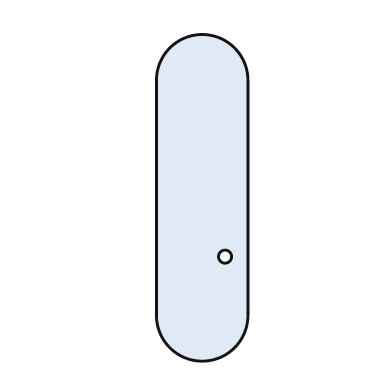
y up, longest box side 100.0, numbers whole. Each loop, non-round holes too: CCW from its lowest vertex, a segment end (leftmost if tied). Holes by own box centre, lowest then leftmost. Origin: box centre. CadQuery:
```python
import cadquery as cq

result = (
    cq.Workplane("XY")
    .moveTo(-14.0, -36.0)
    .threePointArc((0.0, -50.0), (14.0, -36.0))
    .lineTo(14.0, 36.0)
    .threePointArc((0.0, 50.0), (-14.0, 36.0))
    .close()
    .moveTo(7.0, -18.0)
    .circle(2.0)
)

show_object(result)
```